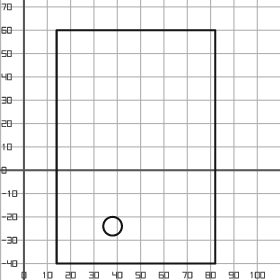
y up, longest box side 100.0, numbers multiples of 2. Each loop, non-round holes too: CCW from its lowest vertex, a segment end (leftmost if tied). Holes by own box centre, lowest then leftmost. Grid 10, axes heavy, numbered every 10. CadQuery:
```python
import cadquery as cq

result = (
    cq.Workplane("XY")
    .moveTo(14.0, -40.0)
    .lineTo(82.0, -40.0)
    .lineTo(82.0, 60.0)
    .lineTo(14.0, 60.0)
    .close()
    .moveTo(38.0, -24.0)
    .circle(4.0)
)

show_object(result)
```